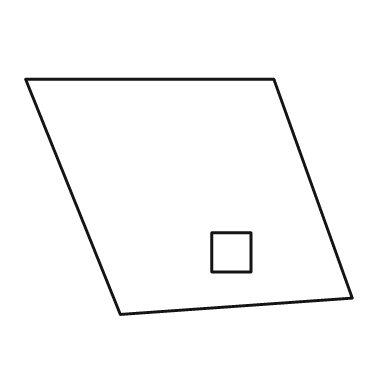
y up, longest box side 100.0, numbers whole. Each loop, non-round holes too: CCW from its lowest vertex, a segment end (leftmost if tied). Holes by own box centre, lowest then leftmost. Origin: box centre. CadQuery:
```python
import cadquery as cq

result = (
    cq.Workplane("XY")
    .moveTo(-21.0, -36.0)
    .lineTo(50.0, -31.0)
    .lineTo(26.0, 36.0)
    .lineTo(-50.0, 36.0)
    .close()
    .moveTo(7.0, -23.0)
    .lineTo(19.0, -23.0)
    .lineTo(19.0, -11.0)
    .lineTo(7.0, -11.0)
    .close()
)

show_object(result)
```